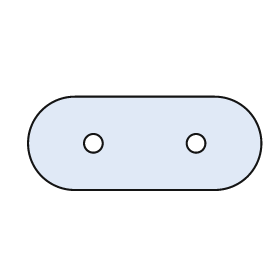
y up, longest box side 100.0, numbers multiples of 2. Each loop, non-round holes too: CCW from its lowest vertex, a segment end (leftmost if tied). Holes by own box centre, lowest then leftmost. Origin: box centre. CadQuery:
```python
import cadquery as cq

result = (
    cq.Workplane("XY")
    .moveTo(-30.0, -20.0)
    .lineTo(30.0, -20.0)
    .threePointArc((50.0, 0.0), (30.0, 20.0))
    .lineTo(-30.0, 20.0)
    .threePointArc((-50.0, 0.0), (-30.0, -20.0))
    .close()
    .moveTo(-22.0, 0.0)
    .circle(4.0)
    .moveTo(22.0, 0.0)
    .circle(4.0)
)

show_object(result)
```